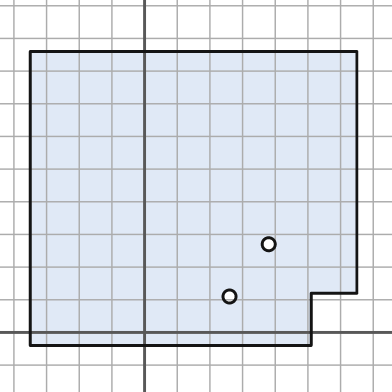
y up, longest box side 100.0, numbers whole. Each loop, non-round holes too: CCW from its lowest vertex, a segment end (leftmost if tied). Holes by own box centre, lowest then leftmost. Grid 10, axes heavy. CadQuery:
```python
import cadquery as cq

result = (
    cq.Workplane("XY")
    .moveTo(-35.0, -4.0)
    .lineTo(51.0, -4.0)
    .lineTo(51.0, 12.0)
    .lineTo(65.0, 12.0)
    .lineTo(65.0, 86.0)
    .lineTo(-35.0, 86.0)
    .close()
    .moveTo(26.0, 11.0)
    .circle(2.0)
    .moveTo(38.0, 27.0)
    .circle(2.0)
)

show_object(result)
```